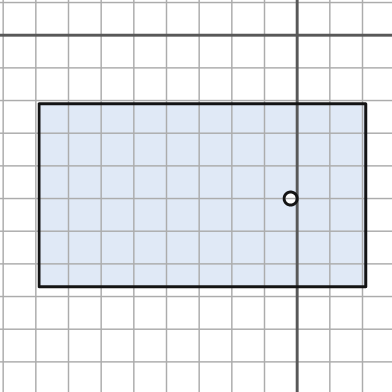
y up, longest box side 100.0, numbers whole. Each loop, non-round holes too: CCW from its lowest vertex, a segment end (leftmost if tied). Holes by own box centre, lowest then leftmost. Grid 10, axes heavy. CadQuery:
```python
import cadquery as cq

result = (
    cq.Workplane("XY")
    .moveTo(-79.0, -77.0)
    .lineTo(21.0, -77.0)
    .lineTo(21.0, -21.0)
    .lineTo(-79.0, -21.0)
    .close()
    .moveTo(-2.0, -50.0)
    .circle(2.0)
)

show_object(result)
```